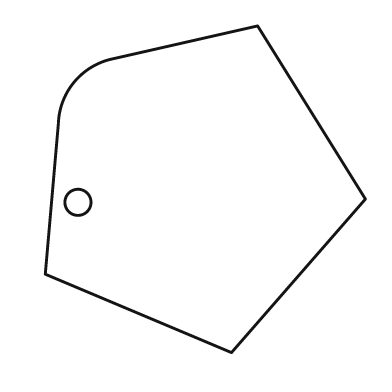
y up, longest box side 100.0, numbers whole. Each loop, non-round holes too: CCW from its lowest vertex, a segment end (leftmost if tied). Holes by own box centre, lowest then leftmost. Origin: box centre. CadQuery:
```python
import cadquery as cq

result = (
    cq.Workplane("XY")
    .moveTo(8.0, -50.0)
    .lineTo(49.0, -3.0)
    .lineTo(16.0, 50.0)
    .lineTo(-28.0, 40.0)
    .threePointArc((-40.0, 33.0), (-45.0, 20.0))
    .lineTo(-49.0, -26.0)
    .close()
    .moveTo(-39.0, -4.0)
    .circle(4.0)
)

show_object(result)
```